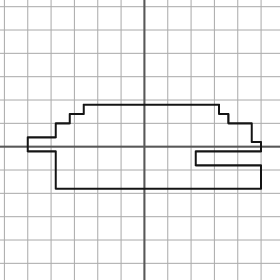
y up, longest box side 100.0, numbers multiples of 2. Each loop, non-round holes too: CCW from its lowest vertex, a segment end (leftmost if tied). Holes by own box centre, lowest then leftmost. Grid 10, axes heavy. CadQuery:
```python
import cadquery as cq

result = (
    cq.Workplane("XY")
    .moveTo(-38.0, -18.0)
    .lineTo(50.0, -18.0)
    .lineTo(50.0, -8.0)
    .lineTo(22.0, -8.0)
    .lineTo(22.0, -2.0)
    .lineTo(50.0, -2.0)
    .lineTo(50.0, 2.0)
    .lineTo(46.0, 2.0)
    .lineTo(46.0, 10.0)
    .lineTo(36.0, 10.0)
    .lineTo(36.0, 14.0)
    .lineTo(32.0, 14.0)
    .lineTo(32.0, 18.0)
    .lineTo(-26.0, 18.0)
    .lineTo(-26.0, 14.0)
    .lineTo(-32.0, 14.0)
    .lineTo(-32.0, 10.0)
    .lineTo(-38.0, 10.0)
    .lineTo(-38.0, 4.0)
    .lineTo(-50.0, 4.0)
    .lineTo(-50.0, -2.0)
    .lineTo(-38.0, -2.0)
    .close()
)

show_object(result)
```